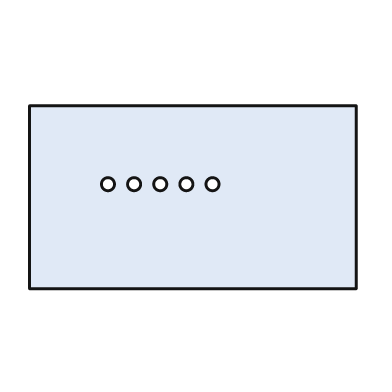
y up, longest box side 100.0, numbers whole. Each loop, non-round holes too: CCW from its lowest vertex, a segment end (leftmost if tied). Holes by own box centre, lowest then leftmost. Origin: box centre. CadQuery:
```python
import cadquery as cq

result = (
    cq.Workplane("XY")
    .moveTo(-50.0, -28.0)
    .lineTo(50.0, -28.0)
    .lineTo(50.0, 28.0)
    .lineTo(-50.0, 28.0)
    .close()
    .moveTo(-26.0, 4.0)
    .circle(2.0)
    .moveTo(-18.0, 4.0)
    .circle(2.0)
    .moveTo(-10.0, 4.0)
    .circle(2.0)
    .moveTo(-2.0, 4.0)
    .circle(2.0)
    .moveTo(6.0, 4.0)
    .circle(2.0)
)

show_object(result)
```